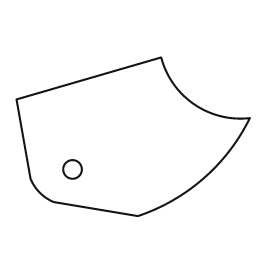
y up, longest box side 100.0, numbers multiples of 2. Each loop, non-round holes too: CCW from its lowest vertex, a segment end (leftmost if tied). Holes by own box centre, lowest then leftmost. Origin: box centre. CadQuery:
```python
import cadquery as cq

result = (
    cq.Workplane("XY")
    .moveTo(2.0, -34.0)
    .threePointArc((30.0, -18.0), (50.0, 8.0))
    .threePointArc((26.0, 14.0), (12.0, 34.0))
    .lineTo(-50.0, 16.0)
    .lineTo(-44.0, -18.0)
    .threePointArc((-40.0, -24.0), (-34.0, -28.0))
    .close()
    .moveTo(-26.0, -14.0)
    .circle(4.0)
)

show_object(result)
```